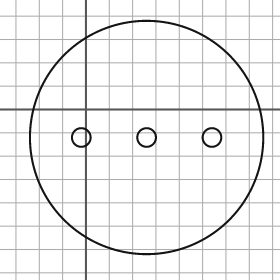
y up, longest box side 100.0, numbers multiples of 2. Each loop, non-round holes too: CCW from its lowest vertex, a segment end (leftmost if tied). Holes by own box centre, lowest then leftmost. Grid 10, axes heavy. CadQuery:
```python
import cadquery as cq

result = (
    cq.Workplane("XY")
    .moveTo(26.0, -12.0)
    .circle(50.0)
    .moveTo(-2.0, -12.0)
    .circle(4.0)
    .moveTo(26.0, -12.0)
    .circle(4.0)
    .moveTo(54.0, -12.0)
    .circle(4.0)
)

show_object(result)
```